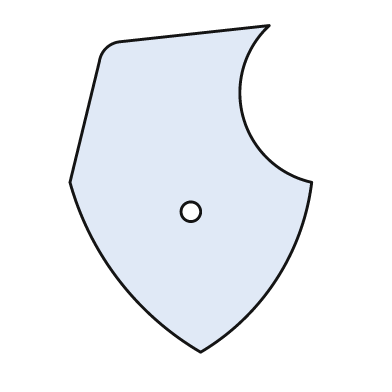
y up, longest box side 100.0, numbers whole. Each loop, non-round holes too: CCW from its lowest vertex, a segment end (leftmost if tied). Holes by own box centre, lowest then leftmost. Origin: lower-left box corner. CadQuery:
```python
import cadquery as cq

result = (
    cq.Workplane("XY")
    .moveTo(40.0, 0.0)
    .threePointArc((63.0, 22.0), (74.0, 52.0))
    .threePointArc((53.0, 72.0), (61.0, 100.0))
    .lineTo(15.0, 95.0)
    .threePointArc((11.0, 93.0), (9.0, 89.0))
    .lineTo(0.0, 52.0)
    .threePointArc((15.0, 22.0), (40.0, 0.0))
    .close()
    .moveTo(37.0, 43.0)
    .circle(3.0)
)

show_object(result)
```